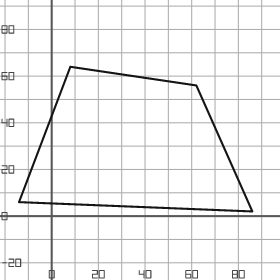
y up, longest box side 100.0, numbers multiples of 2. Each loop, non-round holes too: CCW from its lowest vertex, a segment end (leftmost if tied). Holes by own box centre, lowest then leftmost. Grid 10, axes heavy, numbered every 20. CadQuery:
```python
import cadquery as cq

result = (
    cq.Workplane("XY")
    .moveTo(86.0, 2.0)
    .lineTo(62.0, 56.0)
    .lineTo(8.0, 64.0)
    .lineTo(-14.0, 6.0)
    .close()
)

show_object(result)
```